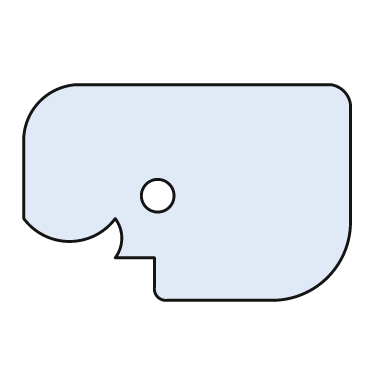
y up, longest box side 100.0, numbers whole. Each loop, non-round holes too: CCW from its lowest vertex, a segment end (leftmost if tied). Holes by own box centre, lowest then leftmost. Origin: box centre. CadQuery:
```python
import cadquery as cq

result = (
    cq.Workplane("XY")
    .moveTo(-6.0, -33.0)
    .lineTo(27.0, -33.0)
    .threePointArc((43.0, -26.0), (50.0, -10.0))
    .lineTo(50.0, 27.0)
    .threePointArc((48.0, 31.0), (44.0, 33.0))
    .lineTo(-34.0, 33.0)
    .threePointArc((-45.0, 28.0), (-50.0, 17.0))
    .lineTo(-50.0, -8.0)
    .threePointArc((-36.0, -15.0), (-22.0, -8.0))
    .threePointArc((-20.0, -14.0), (-22.0, -20.0))
    .lineTo(-10.0, -20.0)
    .lineTo(-10.0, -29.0)
    .threePointArc((-9.0, -32.0), (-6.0, -33.0))
    .close()
    .moveTo(-9.0, -1.0)
    .circle(5.0)
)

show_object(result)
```